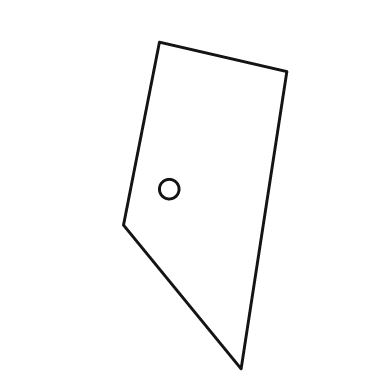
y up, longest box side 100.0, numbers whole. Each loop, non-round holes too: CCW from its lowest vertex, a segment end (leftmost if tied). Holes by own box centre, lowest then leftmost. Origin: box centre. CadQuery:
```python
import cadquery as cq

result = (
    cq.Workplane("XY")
    .moveTo(11.0, -50.0)
    .lineTo(25.0, 41.0)
    .lineTo(-14.0, 50.0)
    .lineTo(-25.0, -6.0)
    .close()
    .moveTo(-11.0, 5.0)
    .circle(3.0)
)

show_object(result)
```